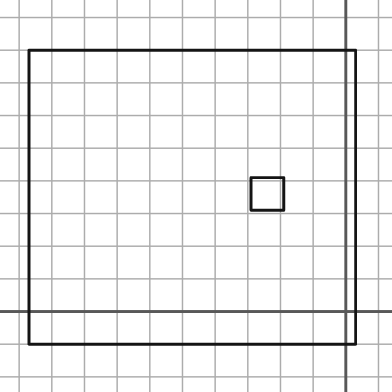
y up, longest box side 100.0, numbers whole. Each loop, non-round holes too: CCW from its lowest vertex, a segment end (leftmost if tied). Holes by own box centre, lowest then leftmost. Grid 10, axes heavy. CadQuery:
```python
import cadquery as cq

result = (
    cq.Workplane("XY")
    .moveTo(-97.0, -10.0)
    .lineTo(3.0, -10.0)
    .lineTo(3.0, 80.0)
    .lineTo(-97.0, 80.0)
    .close()
    .moveTo(-29.0, 31.0)
    .lineTo(-19.0, 31.0)
    .lineTo(-19.0, 41.0)
    .lineTo(-29.0, 41.0)
    .close()
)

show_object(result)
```